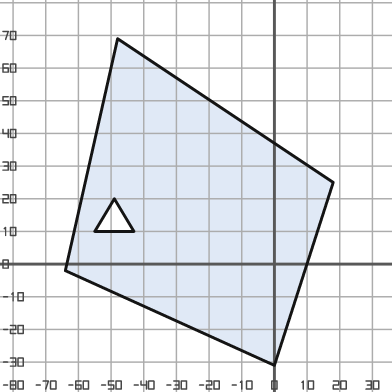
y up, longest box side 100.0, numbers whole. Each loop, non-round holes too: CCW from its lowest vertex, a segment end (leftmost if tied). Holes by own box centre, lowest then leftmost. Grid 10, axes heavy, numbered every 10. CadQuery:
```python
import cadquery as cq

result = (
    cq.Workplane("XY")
    .moveTo(0.0, -31.0)
    .lineTo(18.0, 25.0)
    .lineTo(-48.0, 69.0)
    .lineTo(-64.0, -2.0)
    .close()
    .moveTo(-55.0, 10.0)
    .lineTo(-43.0, 10.0)
    .lineTo(-49.0, 20.0)
    .close()
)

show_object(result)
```